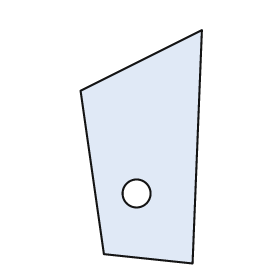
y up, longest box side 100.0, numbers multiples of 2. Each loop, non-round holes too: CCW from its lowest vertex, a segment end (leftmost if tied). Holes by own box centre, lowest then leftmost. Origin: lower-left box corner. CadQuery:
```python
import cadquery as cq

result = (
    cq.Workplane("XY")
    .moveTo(48.0, 0.0)
    .lineTo(52.0, 100.0)
    .lineTo(0.0, 74.0)
    .lineTo(10.0, 4.0)
    .close()
    .moveTo(24.0, 30.0)
    .circle(6.0)
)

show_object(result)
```